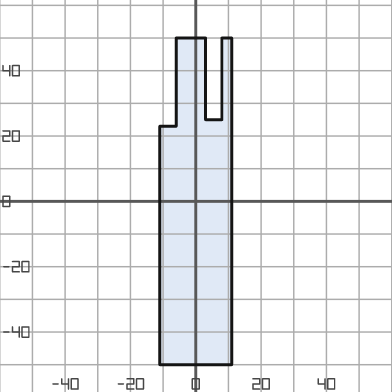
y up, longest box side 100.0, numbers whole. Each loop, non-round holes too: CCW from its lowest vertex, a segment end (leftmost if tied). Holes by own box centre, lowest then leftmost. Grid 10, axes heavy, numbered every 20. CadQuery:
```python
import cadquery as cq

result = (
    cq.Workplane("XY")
    .moveTo(-11.0, -50.0)
    .lineTo(11.0, -50.0)
    .lineTo(11.0, 50.0)
    .lineTo(8.0, 50.0)
    .lineTo(8.0, 25.0)
    .lineTo(3.0, 25.0)
    .lineTo(3.0, 50.0)
    .lineTo(-6.0, 50.0)
    .lineTo(-6.0, 23.0)
    .lineTo(-11.0, 23.0)
    .close()
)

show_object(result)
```